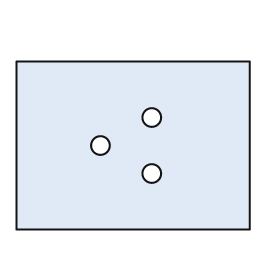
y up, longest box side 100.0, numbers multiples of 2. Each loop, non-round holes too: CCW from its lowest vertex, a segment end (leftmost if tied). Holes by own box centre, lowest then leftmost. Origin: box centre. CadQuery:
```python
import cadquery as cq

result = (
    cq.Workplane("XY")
    .moveTo(-50.0, -36.0)
    .lineTo(50.0, -36.0)
    .lineTo(50.0, 36.0)
    .lineTo(-50.0, 36.0)
    .close()
    .moveTo(8.0, -12.0)
    .circle(4.0)
    .moveTo(-14.0, 0.0)
    .circle(4.0)
    .moveTo(8.0, 12.0)
    .circle(4.0)
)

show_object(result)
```